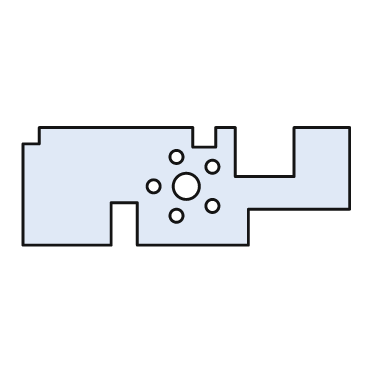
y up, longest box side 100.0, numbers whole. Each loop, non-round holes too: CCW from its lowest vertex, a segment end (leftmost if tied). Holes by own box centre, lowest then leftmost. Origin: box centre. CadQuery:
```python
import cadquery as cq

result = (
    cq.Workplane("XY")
    .moveTo(-50.0, -18.0)
    .lineTo(-23.0, -18.0)
    .lineTo(-23.0, -5.0)
    .lineTo(-15.0, -5.0)
    .lineTo(-15.0, -18.0)
    .lineTo(19.0, -18.0)
    .lineTo(19.0, -7.0)
    .lineTo(50.0, -7.0)
    .lineTo(50.0, 18.0)
    .lineTo(33.0, 18.0)
    .lineTo(33.0, 3.0)
    .lineTo(15.0, 3.0)
    .lineTo(15.0, 18.0)
    .lineTo(9.0, 18.0)
    .lineTo(9.0, 12.0)
    .lineTo(2.0, 12.0)
    .lineTo(2.0, 18.0)
    .lineTo(-45.0, 18.0)
    .lineTo(-45.0, 13.0)
    .lineTo(-50.0, 13.0)
    .close()
    .moveTo(-3.0, -9.0)
    .circle(2.0)
    .moveTo(8.0, -6.0)
    .circle(2.0)
    .moveTo(-10.0, 0.0)
    .circle(2.0)
    .moveTo(0.0, 0.0)
    .circle(4.0)
    .moveTo(8.0, 6.0)
    .circle(2.0)
    .moveTo(-3.0, 9.0)
    .circle(2.0)
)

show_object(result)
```